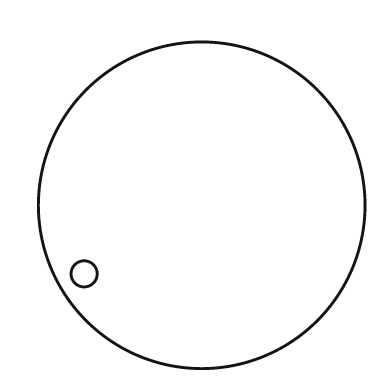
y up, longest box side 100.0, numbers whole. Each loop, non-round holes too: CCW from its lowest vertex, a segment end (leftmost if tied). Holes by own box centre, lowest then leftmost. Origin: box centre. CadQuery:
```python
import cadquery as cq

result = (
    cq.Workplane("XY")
    .moveTo(0.0, 0.0)
    .circle(50.0)
    .moveTo(-36.0, -21.0)
    .circle(4.0)
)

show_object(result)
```